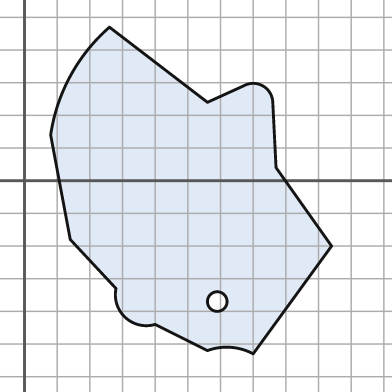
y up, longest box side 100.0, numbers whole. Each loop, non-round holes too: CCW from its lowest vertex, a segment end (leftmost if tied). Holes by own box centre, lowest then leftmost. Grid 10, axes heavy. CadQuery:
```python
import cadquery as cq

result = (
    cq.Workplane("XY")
    .moveTo(70.0, -53.0)
    .lineTo(94.0, -20.0)
    .lineTo(77.0, 4.0)
    .lineTo(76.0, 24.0)
    .threePointArc((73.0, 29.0), (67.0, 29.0))
    .lineTo(56.0, 24.0)
    .lineTo(26.0, 47.0)
    .threePointArc((14.0, 32.0), (8.0, 14.0))
    .lineTo(14.0, -18.0)
    .lineTo(28.0, -33.0)
    .threePointArc((31.0, -42.0), (40.0, -44.0))
    .lineTo(56.0, -52.0)
    .threePointArc((63.0, -51.0), (70.0, -53.0))
    .close()
    .moveTo(59.0, -37.0)
    .circle(3.0)
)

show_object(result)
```